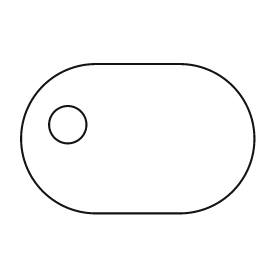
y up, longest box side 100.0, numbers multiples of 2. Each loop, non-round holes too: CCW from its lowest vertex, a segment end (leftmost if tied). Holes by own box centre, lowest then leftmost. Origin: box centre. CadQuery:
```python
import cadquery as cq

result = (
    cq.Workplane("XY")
    .moveTo(-18.0, -32.0)
    .lineTo(18.0, -32.0)
    .threePointArc((50.0, 0.0), (18.0, 32.0))
    .lineTo(-18.0, 32.0)
    .threePointArc((-50.0, 0.0), (-18.0, -32.0))
    .close()
    .moveTo(-30.0, 6.0)
    .circle(8.0)
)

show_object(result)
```